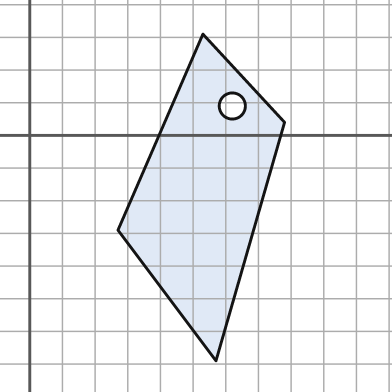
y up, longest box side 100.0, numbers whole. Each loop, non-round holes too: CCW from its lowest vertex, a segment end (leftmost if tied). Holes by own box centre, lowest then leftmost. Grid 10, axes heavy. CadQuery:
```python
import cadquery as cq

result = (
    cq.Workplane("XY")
    .moveTo(57.0, -69.0)
    .lineTo(78.0, 4.0)
    .lineTo(53.0, 31.0)
    .lineTo(27.0, -29.0)
    .close()
    .moveTo(62.0, 9.0)
    .circle(4.0)
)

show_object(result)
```